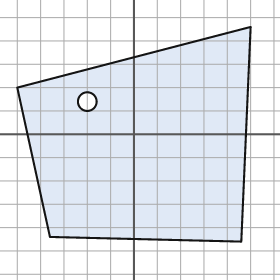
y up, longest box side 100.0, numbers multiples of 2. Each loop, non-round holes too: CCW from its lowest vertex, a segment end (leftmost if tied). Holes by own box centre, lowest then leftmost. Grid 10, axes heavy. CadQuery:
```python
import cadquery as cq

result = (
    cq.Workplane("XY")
    .moveTo(46.0, -46.0)
    .lineTo(50.0, 46.0)
    .lineTo(-50.0, 20.0)
    .lineTo(-36.0, -44.0)
    .close()
    .moveTo(-20.0, 14.0)
    .circle(4.0)
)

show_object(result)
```